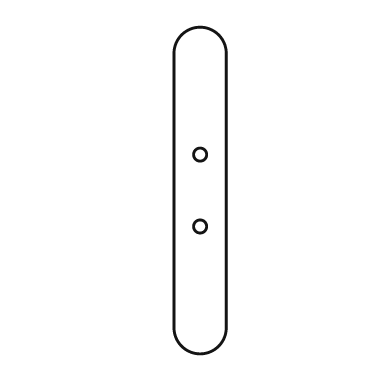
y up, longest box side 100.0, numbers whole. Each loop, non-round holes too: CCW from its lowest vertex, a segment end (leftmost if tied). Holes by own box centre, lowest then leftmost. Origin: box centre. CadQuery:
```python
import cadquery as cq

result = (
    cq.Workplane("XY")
    .moveTo(-8.0, -42.0)
    .threePointArc((0.0, -50.0), (8.0, -42.0))
    .lineTo(8.0, 42.0)
    .threePointArc((0.0, 50.0), (-8.0, 42.0))
    .close()
    .moveTo(0.0, -11.0)
    .circle(2.0)
    .moveTo(0.0, 11.0)
    .circle(2.0)
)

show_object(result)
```